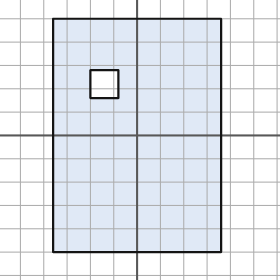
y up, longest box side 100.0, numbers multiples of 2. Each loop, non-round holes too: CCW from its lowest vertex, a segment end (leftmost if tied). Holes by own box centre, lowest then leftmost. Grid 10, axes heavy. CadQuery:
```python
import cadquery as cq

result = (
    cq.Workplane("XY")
    .moveTo(-36.0, -50.0)
    .lineTo(36.0, -50.0)
    .lineTo(36.0, 50.0)
    .lineTo(-36.0, 50.0)
    .close()
    .moveTo(-20.0, 16.0)
    .lineTo(-8.0, 16.0)
    .lineTo(-8.0, 28.0)
    .lineTo(-20.0, 28.0)
    .close()
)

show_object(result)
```